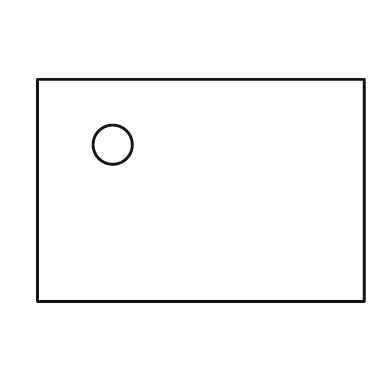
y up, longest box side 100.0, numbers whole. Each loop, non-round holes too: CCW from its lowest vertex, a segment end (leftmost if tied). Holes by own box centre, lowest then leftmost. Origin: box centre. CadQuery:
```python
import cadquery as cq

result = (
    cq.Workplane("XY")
    .moveTo(-50.0, -34.0)
    .lineTo(50.0, -34.0)
    .lineTo(50.0, 34.0)
    .lineTo(-50.0, 34.0)
    .close()
    .moveTo(-27.0, 14.0)
    .circle(6.0)
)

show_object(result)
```